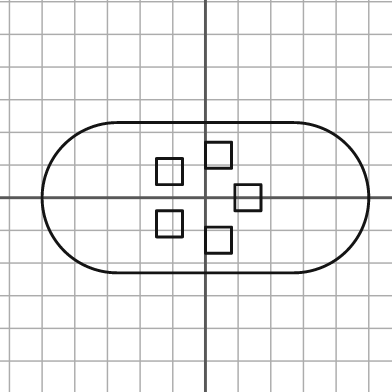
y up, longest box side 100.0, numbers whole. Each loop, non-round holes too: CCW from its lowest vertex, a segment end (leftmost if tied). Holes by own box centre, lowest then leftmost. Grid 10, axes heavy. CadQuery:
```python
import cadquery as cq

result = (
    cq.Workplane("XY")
    .moveTo(-27.0, -23.0)
    .lineTo(27.0, -23.0)
    .threePointArc((50.0, 0.0), (27.0, 23.0))
    .lineTo(-27.0, 23.0)
    .threePointArc((-50.0, 0.0), (-27.0, -23.0))
    .close()
    .moveTo(0.0, -17.0)
    .lineTo(8.0, -17.0)
    .lineTo(8.0, -9.0)
    .lineTo(0.0, -9.0)
    .close()
    .moveTo(-15.0, -12.0)
    .lineTo(-7.0, -12.0)
    .lineTo(-7.0, -4.0)
    .lineTo(-15.0, -4.0)
    .close()
    .moveTo(9.0, -4.0)
    .lineTo(17.0, -4.0)
    .lineTo(17.0, 4.0)
    .lineTo(9.0, 4.0)
    .close()
    .moveTo(-15.0, 4.0)
    .lineTo(-7.0, 4.0)
    .lineTo(-7.0, 12.0)
    .lineTo(-15.0, 12.0)
    .close()
    .moveTo(0.0, 9.0)
    .lineTo(8.0, 9.0)
    .lineTo(8.0, 17.0)
    .lineTo(0.0, 17.0)
    .close()
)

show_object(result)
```